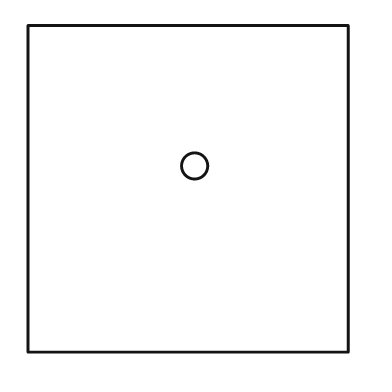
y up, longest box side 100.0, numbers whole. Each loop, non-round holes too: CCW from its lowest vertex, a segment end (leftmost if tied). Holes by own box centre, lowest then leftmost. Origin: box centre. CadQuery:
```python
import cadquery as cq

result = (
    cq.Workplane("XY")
    .moveTo(-49.0, -50.0)
    .lineTo(49.0, -50.0)
    .lineTo(49.0, 50.0)
    .lineTo(-49.0, 50.0)
    .close()
    .moveTo(2.0, 7.0)
    .circle(4.0)
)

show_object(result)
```